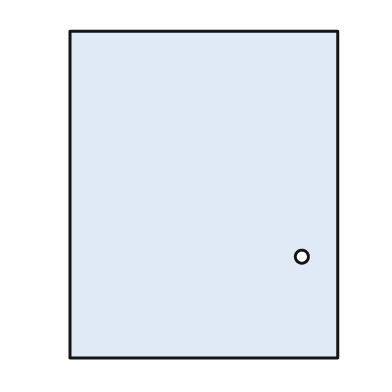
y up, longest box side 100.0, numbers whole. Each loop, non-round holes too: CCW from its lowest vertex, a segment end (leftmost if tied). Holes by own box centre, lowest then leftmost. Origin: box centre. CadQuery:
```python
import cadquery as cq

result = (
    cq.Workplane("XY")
    .moveTo(-41.0, -50.0)
    .lineTo(41.0, -50.0)
    .lineTo(41.0, 50.0)
    .lineTo(-41.0, 50.0)
    .close()
    .moveTo(30.0, -19.0)
    .circle(2.0)
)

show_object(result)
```